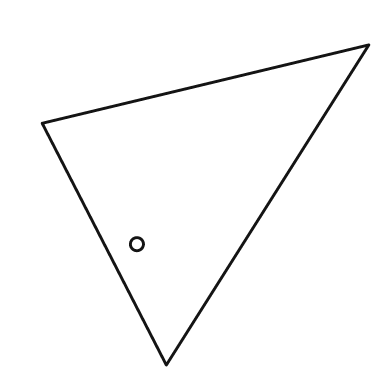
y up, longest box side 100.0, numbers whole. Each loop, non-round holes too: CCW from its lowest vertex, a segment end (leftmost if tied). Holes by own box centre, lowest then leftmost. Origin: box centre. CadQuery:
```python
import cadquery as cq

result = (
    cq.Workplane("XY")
    .moveTo(-12.0, -49.0)
    .lineTo(50.0, 49.0)
    .lineTo(-50.0, 25.0)
    .close()
    .moveTo(-21.0, -12.0)
    .circle(2.0)
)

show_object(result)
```